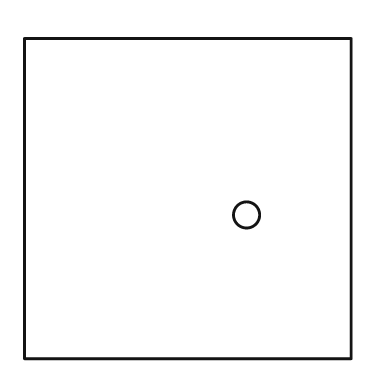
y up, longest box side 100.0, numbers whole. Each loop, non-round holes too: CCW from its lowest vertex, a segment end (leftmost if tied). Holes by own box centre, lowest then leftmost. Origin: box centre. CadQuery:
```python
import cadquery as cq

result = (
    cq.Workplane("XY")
    .moveTo(-50.0, -49.0)
    .lineTo(50.0, -49.0)
    .lineTo(50.0, 49.0)
    .lineTo(-50.0, 49.0)
    .close()
    .moveTo(18.0, -5.0)
    .circle(4.0)
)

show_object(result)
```